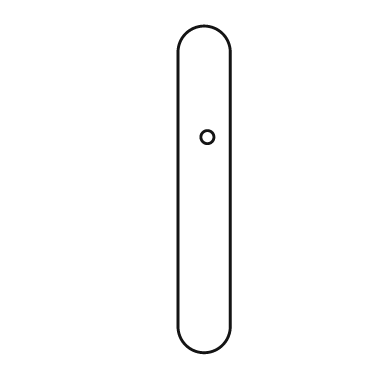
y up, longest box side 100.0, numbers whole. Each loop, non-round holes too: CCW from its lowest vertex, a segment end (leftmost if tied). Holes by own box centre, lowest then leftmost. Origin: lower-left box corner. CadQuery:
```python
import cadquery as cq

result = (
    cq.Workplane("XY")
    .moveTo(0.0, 8.0)
    .threePointArc((8.0, 0.0), (16.0, 8.0))
    .lineTo(16.0, 92.0)
    .threePointArc((8.0, 100.0), (0.0, 92.0))
    .close()
    .moveTo(9.0, 66.0)
    .circle(2.0)
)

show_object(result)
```